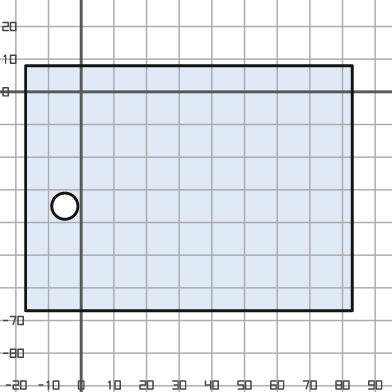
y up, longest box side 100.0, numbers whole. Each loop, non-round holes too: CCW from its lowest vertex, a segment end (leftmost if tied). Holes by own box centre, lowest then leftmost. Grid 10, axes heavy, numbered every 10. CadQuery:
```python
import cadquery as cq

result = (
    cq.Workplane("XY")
    .moveTo(-17.0, -67.0)
    .lineTo(83.0, -67.0)
    .lineTo(83.0, 8.0)
    .lineTo(-17.0, 8.0)
    .close()
    .moveTo(-5.0, -35.0)
    .circle(4.0)
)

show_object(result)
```